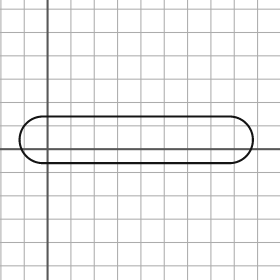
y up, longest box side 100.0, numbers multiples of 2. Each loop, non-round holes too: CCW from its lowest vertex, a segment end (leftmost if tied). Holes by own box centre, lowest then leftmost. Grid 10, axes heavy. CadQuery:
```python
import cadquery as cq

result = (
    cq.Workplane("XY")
    .moveTo(-2.0, -6.0)
    .lineTo(78.0, -6.0)
    .threePointArc((88.0, 4.0), (78.0, 14.0))
    .lineTo(-2.0, 14.0)
    .threePointArc((-12.0, 4.0), (-2.0, -6.0))
    .close()
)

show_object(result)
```